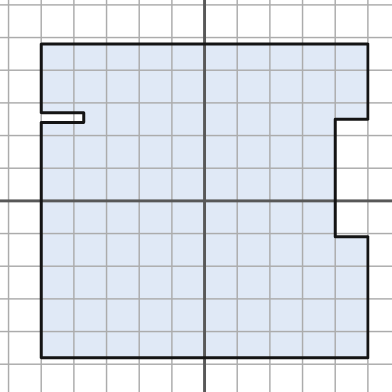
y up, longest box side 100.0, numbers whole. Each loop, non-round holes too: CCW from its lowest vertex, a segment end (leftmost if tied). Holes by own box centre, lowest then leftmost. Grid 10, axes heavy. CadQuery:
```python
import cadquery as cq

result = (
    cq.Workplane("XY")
    .moveTo(-50.0, -48.0)
    .lineTo(50.0, -48.0)
    .lineTo(50.0, -11.0)
    .lineTo(40.0, -11.0)
    .lineTo(40.0, 25.0)
    .lineTo(50.0, 25.0)
    .lineTo(50.0, 48.0)
    .lineTo(-50.0, 48.0)
    .lineTo(-50.0, 27.0)
    .lineTo(-37.0, 27.0)
    .lineTo(-37.0, 24.0)
    .lineTo(-50.0, 24.0)
    .close()
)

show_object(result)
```